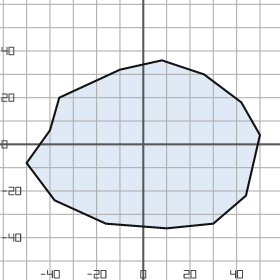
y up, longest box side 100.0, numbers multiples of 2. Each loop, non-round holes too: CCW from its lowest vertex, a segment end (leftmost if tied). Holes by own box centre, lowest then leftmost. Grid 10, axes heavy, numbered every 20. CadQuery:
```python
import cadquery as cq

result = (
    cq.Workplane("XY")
    .moveTo(10.0, -36.0)
    .lineTo(30.0, -34.0)
    .lineTo(44.0, -22.0)
    .lineTo(50.0, 4.0)
    .lineTo(42.0, 18.0)
    .lineTo(26.0, 30.0)
    .lineTo(8.0, 36.0)
    .lineTo(-10.0, 32.0)
    .lineTo(-36.0, 20.0)
    .lineTo(-40.0, 6.0)
    .lineTo(-50.0, -8.0)
    .lineTo(-38.0, -24.0)
    .lineTo(-16.0, -34.0)
    .close()
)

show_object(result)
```